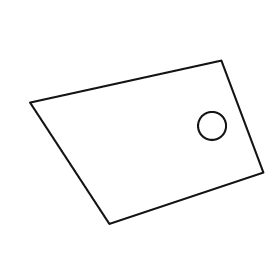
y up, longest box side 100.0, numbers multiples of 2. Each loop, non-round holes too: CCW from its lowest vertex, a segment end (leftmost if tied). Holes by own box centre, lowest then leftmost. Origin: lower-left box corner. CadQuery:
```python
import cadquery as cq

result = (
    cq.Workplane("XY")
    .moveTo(34.0, 0.0)
    .lineTo(100.0, 22.0)
    .lineTo(82.0, 70.0)
    .lineTo(0.0, 52.0)
    .close()
    .moveTo(78.0, 42.0)
    .circle(6.0)
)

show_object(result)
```